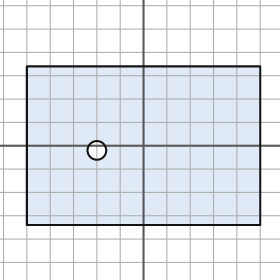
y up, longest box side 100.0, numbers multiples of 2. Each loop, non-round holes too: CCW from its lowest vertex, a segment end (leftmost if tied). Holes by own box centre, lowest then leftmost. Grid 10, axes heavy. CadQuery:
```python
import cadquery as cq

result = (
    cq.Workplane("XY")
    .moveTo(-50.0, -34.0)
    .lineTo(50.0, -34.0)
    .lineTo(50.0, 34.0)
    .lineTo(-50.0, 34.0)
    .close()
    .moveTo(-20.0, -2.0)
    .circle(4.0)
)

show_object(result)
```